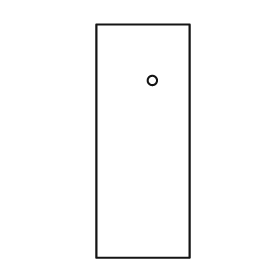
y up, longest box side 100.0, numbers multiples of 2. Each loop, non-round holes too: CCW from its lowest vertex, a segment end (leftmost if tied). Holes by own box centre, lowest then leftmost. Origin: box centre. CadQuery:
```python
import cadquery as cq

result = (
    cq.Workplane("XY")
    .moveTo(-20.0, -50.0)
    .lineTo(20.0, -50.0)
    .lineTo(20.0, 50.0)
    .lineTo(-20.0, 50.0)
    .close()
    .moveTo(4.0, 26.0)
    .circle(2.0)
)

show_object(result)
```